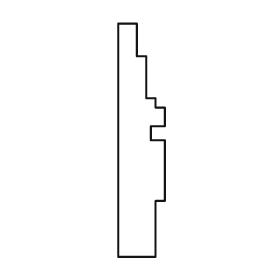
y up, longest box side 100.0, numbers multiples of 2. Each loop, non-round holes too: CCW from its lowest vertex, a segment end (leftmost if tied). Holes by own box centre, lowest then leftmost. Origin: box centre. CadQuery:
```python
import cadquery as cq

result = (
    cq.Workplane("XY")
    .moveTo(-10.0, -50.0)
    .lineTo(6.0, -50.0)
    .lineTo(6.0, -26.0)
    .lineTo(10.0, -26.0)
    .lineTo(10.0, 0.0)
    .lineTo(4.0, 0.0)
    .lineTo(4.0, 6.0)
    .lineTo(10.0, 6.0)
    .lineTo(10.0, 14.0)
    .lineTo(6.0, 14.0)
    .lineTo(6.0, 18.0)
    .lineTo(2.0, 18.0)
    .lineTo(2.0, 36.0)
    .lineTo(-2.0, 36.0)
    .lineTo(-2.0, 50.0)
    .lineTo(-10.0, 50.0)
    .close()
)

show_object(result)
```